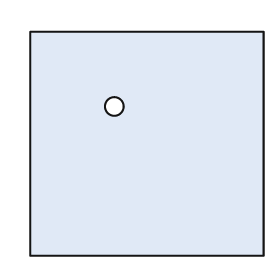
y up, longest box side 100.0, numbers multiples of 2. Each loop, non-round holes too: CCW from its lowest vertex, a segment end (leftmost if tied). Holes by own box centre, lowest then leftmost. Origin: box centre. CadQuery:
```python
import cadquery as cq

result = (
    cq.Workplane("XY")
    .moveTo(-50.0, -48.0)
    .lineTo(50.0, -48.0)
    .lineTo(50.0, 48.0)
    .lineTo(-50.0, 48.0)
    .close()
    .moveTo(-14.0, 16.0)
    .circle(4.0)
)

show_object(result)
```